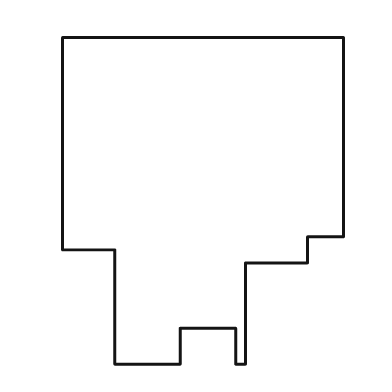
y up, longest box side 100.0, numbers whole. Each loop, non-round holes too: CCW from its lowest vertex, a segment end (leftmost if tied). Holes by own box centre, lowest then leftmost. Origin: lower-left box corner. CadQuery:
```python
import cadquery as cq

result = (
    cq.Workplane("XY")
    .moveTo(16.0, 0.0)
    .lineTo(36.0, 0.0)
    .lineTo(36.0, 11.0)
    .lineTo(53.0, 11.0)
    .lineTo(53.0, 0.0)
    .lineTo(56.0, 0.0)
    .lineTo(56.0, 31.0)
    .lineTo(75.0, 31.0)
    .lineTo(75.0, 39.0)
    .lineTo(86.0, 39.0)
    .lineTo(86.0, 100.0)
    .lineTo(0.0, 100.0)
    .lineTo(0.0, 35.0)
    .lineTo(16.0, 35.0)
    .close()
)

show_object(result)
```